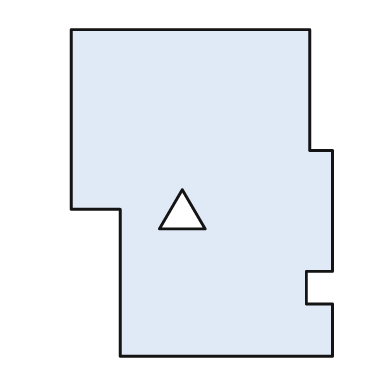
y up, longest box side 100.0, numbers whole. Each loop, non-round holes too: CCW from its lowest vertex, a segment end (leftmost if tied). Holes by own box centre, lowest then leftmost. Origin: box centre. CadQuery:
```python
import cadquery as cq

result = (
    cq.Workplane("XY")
    .moveTo(-25.0, -50.0)
    .lineTo(40.0, -50.0)
    .lineTo(40.0, -34.0)
    .lineTo(32.0, -34.0)
    .lineTo(32.0, -24.0)
    .lineTo(40.0, -24.0)
    .lineTo(40.0, 13.0)
    .lineTo(33.0, 13.0)
    .lineTo(33.0, 50.0)
    .lineTo(-40.0, 50.0)
    .lineTo(-40.0, -5.0)
    .lineTo(-25.0, -5.0)
    .close()
    .moveTo(-13.0, -11.0)
    .lineTo(1.0, -11.0)
    .lineTo(-6.0, 1.0)
    .close()
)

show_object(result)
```